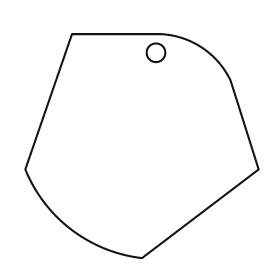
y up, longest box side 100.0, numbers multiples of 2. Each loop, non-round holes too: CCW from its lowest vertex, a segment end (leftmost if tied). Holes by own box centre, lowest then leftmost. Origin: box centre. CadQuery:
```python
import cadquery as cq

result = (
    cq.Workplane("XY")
    .moveTo(0.0, -48.0)
    .lineTo(50.0, -10.0)
    .lineTo(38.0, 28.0)
    .threePointArc((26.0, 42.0), (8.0, 48.0))
    .lineTo(-30.0, 48.0)
    .lineTo(-50.0, -10.0)
    .threePointArc((-30.0, -36.0), (0.0, -48.0))
    .close()
    .moveTo(6.0, 40.0)
    .circle(4.0)
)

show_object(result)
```